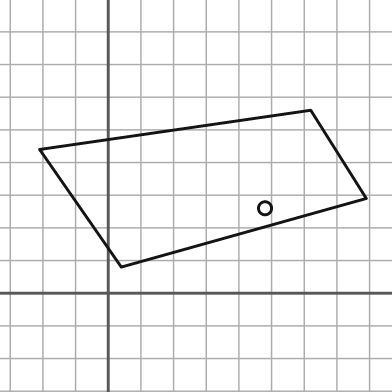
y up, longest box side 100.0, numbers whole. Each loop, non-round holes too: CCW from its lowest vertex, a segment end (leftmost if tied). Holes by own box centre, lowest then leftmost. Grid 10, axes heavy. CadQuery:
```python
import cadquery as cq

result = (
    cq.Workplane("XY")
    .moveTo(4.0, 8.0)
    .lineTo(79.0, 29.0)
    .lineTo(62.0, 56.0)
    .lineTo(-21.0, 44.0)
    .close()
    .moveTo(48.0, 26.0)
    .circle(2.0)
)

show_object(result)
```